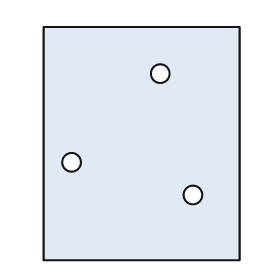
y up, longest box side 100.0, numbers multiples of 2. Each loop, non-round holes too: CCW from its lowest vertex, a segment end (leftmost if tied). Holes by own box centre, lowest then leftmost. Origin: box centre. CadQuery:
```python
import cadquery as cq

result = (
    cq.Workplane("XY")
    .moveTo(-42.0, -50.0)
    .lineTo(42.0, -50.0)
    .lineTo(42.0, 50.0)
    .lineTo(-42.0, 50.0)
    .close()
    .moveTo(22.0, -22.0)
    .circle(4.0)
    .moveTo(-30.0, -8.0)
    .circle(4.0)
    .moveTo(8.0, 30.0)
    .circle(4.0)
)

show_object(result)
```